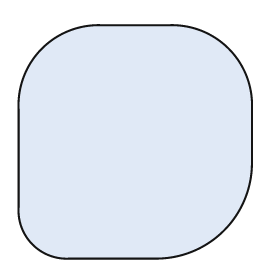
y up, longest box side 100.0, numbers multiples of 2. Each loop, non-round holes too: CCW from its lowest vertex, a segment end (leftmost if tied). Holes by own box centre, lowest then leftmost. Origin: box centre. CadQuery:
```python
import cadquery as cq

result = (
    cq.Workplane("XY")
    .moveTo(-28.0, -50.0)
    .lineTo(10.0, -50.0)
    .threePointArc((38.0, -38.0), (50.0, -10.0))
    .lineTo(50.0, 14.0)
    .threePointArc((40.0, 40.0), (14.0, 50.0))
    .lineTo(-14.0, 50.0)
    .threePointArc((-40.0, 40.0), (-50.0, 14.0))
    .lineTo(-50.0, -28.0)
    .threePointArc((-44.0, -44.0), (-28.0, -50.0))
    .close()
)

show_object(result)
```